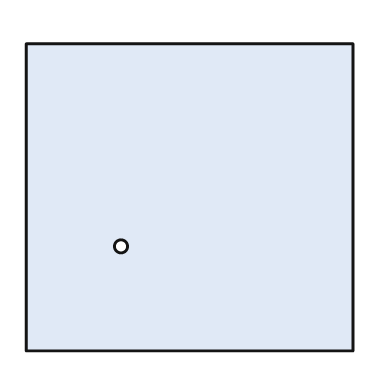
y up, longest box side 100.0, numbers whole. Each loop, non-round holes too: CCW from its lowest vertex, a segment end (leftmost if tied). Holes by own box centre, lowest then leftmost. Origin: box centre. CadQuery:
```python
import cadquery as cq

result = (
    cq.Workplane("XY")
    .moveTo(-50.0, -47.0)
    .lineTo(50.0, -47.0)
    .lineTo(50.0, 47.0)
    .lineTo(-50.0, 47.0)
    .close()
    .moveTo(-21.0, -15.0)
    .circle(2.0)
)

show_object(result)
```